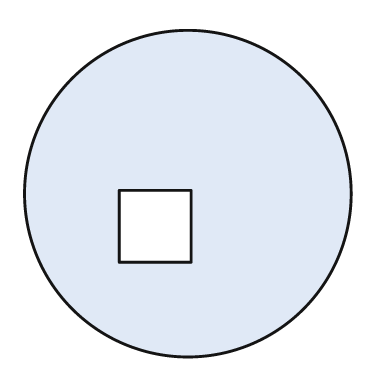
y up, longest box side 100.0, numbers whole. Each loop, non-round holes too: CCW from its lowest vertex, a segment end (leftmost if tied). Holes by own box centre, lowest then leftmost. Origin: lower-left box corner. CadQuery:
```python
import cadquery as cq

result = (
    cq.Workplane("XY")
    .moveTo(50.0, 50.0)
    .circle(50.0)
    .moveTo(29.0, 29.0)
    .lineTo(51.0, 29.0)
    .lineTo(51.0, 51.0)
    .lineTo(29.0, 51.0)
    .close()
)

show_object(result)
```